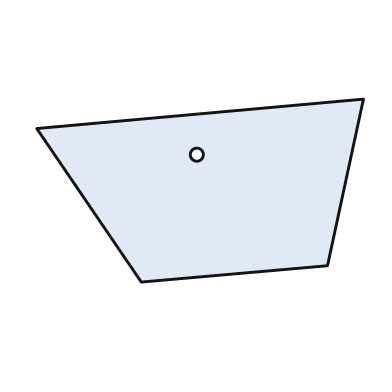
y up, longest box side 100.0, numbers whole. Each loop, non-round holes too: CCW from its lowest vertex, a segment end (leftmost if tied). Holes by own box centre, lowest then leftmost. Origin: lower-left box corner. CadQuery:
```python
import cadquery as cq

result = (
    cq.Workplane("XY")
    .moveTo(32.0, 0.0)
    .lineTo(89.0, 5.0)
    .lineTo(100.0, 56.0)
    .lineTo(0.0, 47.0)
    .close()
    .moveTo(49.0, 39.0)
    .circle(2.0)
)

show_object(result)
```